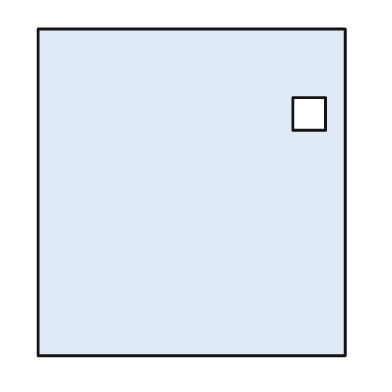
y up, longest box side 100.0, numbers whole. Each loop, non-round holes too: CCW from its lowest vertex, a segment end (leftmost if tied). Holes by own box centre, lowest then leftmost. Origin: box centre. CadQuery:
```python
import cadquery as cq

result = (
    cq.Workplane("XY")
    .moveTo(-47.0, -50.0)
    .lineTo(47.0, -50.0)
    .lineTo(47.0, 50.0)
    .lineTo(-47.0, 50.0)
    .close()
    .moveTo(31.0, 19.0)
    .lineTo(41.0, 19.0)
    .lineTo(41.0, 29.0)
    .lineTo(31.0, 29.0)
    .close()
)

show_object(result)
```